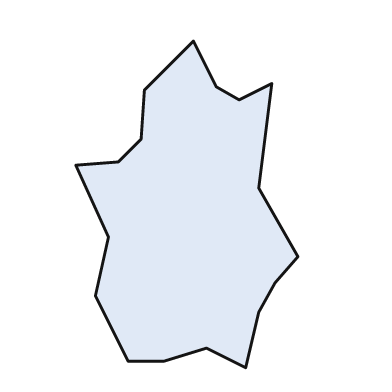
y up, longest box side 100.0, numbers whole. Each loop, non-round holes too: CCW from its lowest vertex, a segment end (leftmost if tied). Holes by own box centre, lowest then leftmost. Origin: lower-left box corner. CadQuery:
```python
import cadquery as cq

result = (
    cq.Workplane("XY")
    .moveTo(52.0, 0.0)
    .lineTo(56.0, 17.0)
    .lineTo(61.0, 26.0)
    .lineTo(68.0, 34.0)
    .lineTo(56.0, 55.0)
    .lineTo(60.0, 87.0)
    .lineTo(50.0, 82.0)
    .lineTo(43.0, 86.0)
    .lineTo(36.0, 100.0)
    .lineTo(21.0, 85.0)
    .lineTo(20.0, 70.0)
    .lineTo(13.0, 63.0)
    .lineTo(0.0, 62.0)
    .lineTo(10.0, 40.0)
    .lineTo(6.0, 22.0)
    .lineTo(16.0, 2.0)
    .lineTo(27.0, 2.0)
    .lineTo(40.0, 6.0)
    .close()
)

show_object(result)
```